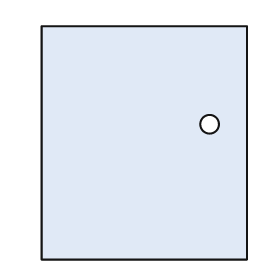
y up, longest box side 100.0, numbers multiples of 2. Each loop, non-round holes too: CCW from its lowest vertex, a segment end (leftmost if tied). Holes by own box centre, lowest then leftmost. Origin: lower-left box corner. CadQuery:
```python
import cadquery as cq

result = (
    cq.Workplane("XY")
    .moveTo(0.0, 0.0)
    .lineTo(88.0, 0.0)
    .lineTo(88.0, 100.0)
    .lineTo(0.0, 100.0)
    .close()
    .moveTo(72.0, 58.0)
    .circle(4.0)
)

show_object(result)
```